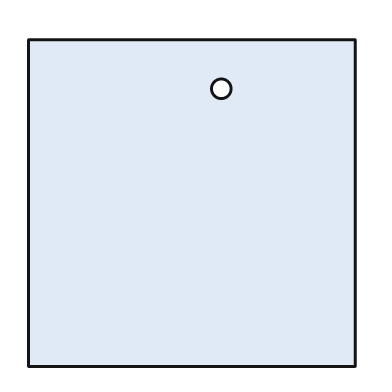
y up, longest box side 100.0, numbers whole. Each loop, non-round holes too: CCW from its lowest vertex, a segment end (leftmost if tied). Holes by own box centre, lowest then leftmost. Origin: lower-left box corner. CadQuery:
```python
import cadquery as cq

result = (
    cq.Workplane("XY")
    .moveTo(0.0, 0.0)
    .lineTo(100.0, 0.0)
    .lineTo(100.0, 100.0)
    .lineTo(0.0, 100.0)
    .close()
    .moveTo(59.0, 85.0)
    .circle(3.0)
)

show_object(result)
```